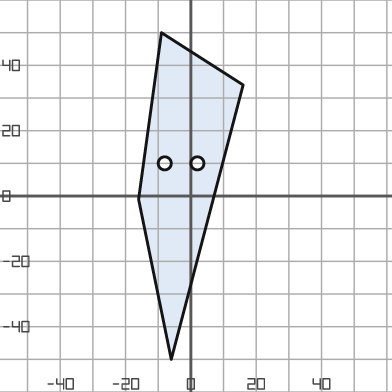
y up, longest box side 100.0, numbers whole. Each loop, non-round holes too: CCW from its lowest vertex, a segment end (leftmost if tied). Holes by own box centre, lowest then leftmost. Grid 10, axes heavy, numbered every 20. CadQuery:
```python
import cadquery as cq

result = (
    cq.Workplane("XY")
    .moveTo(-6.0, -50.0)
    .lineTo(16.0, 34.0)
    .lineTo(-9.0, 50.0)
    .lineTo(-16.0, -1.0)
    .close()
    .moveTo(-8.0, 10.0)
    .circle(2.0)
    .moveTo(2.0, 10.0)
    .circle(2.0)
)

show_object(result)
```